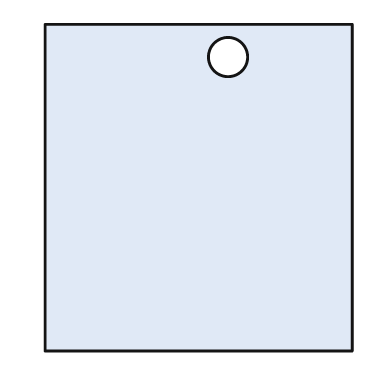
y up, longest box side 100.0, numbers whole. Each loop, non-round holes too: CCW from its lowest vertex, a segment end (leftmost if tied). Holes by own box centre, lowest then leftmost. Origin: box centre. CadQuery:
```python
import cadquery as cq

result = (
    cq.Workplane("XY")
    .moveTo(-47.0, -50.0)
    .lineTo(47.0, -50.0)
    .lineTo(47.0, 50.0)
    .lineTo(-47.0, 50.0)
    .close()
    .moveTo(9.0, 40.0)
    .circle(6.0)
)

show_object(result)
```